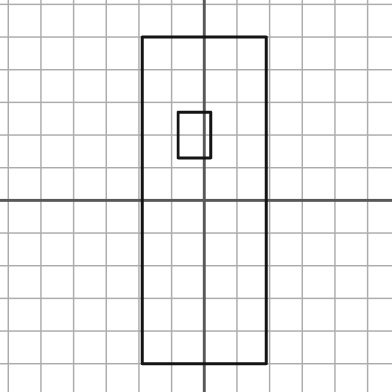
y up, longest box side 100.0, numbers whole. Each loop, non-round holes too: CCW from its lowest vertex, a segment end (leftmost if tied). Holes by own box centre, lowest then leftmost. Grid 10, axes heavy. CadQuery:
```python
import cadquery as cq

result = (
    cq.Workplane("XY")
    .moveTo(-19.0, -50.0)
    .lineTo(19.0, -50.0)
    .lineTo(19.0, 50.0)
    .lineTo(-19.0, 50.0)
    .close()
    .moveTo(-8.0, 13.0)
    .lineTo(2.0, 13.0)
    .lineTo(2.0, 27.0)
    .lineTo(-8.0, 27.0)
    .close()
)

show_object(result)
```